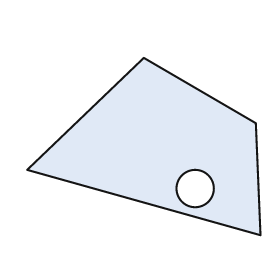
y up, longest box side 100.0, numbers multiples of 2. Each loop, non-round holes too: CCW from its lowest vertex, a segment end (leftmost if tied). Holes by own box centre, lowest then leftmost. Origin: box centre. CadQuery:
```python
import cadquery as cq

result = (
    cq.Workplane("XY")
    .moveTo(50.0, -38.0)
    .lineTo(48.0, 10.0)
    .lineTo(0.0, 38.0)
    .lineTo(-50.0, -10.0)
    .close()
    .moveTo(22.0, -18.0)
    .circle(8.0)
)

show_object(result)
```